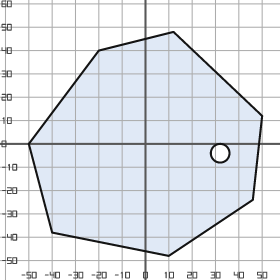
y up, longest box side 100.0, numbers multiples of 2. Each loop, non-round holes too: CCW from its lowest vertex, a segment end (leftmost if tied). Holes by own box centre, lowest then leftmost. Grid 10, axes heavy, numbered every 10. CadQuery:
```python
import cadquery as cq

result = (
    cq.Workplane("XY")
    .moveTo(10.0, -48.0)
    .lineTo(46.0, -24.0)
    .lineTo(50.0, 12.0)
    .lineTo(12.0, 48.0)
    .lineTo(-20.0, 40.0)
    .lineTo(-50.0, 0.0)
    .lineTo(-40.0, -38.0)
    .close()
    .moveTo(32.0, -4.0)
    .circle(4.0)
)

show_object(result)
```